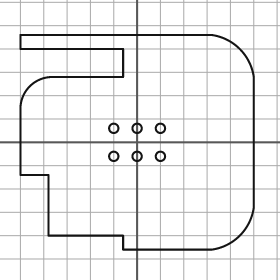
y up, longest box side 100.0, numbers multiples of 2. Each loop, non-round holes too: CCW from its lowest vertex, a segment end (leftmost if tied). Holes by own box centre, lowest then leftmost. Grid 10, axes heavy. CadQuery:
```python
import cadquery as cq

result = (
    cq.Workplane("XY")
    .moveTo(-6.0, -46.0)
    .lineTo(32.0, -46.0)
    .threePointArc((44.0, -40.0), (50.0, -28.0))
    .lineTo(50.0, 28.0)
    .threePointArc((44.0, 40.0), (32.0, 46.0))
    .lineTo(-50.0, 46.0)
    .lineTo(-50.0, 40.0)
    .lineTo(-6.0, 40.0)
    .lineTo(-6.0, 28.0)
    .lineTo(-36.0, 28.0)
    .threePointArc((-46.0, 24.0), (-50.0, 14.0))
    .lineTo(-50.0, -14.0)
    .lineTo(-38.0, -14.0)
    .lineTo(-38.0, -40.0)
    .lineTo(-6.0, -40.0)
    .close()
    .moveTo(-10.0, -6.0)
    .circle(2.0)
    .moveTo(0.0, -6.0)
    .circle(2.0)
    .moveTo(10.0, -6.0)
    .circle(2.0)
    .moveTo(-10.0, 6.0)
    .circle(2.0)
    .moveTo(0.0, 6.0)
    .circle(2.0)
    .moveTo(10.0, 6.0)
    .circle(2.0)
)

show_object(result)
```